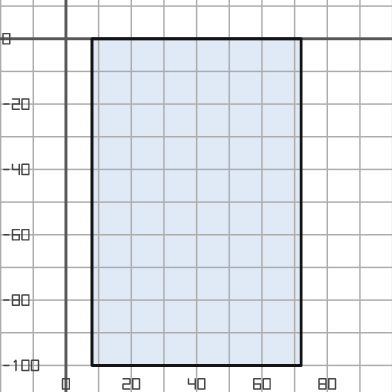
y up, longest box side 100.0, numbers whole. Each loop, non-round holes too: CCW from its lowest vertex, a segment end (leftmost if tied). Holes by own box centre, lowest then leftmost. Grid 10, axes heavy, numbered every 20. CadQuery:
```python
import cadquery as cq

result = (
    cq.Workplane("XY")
    .moveTo(8.0, -100.0)
    .lineTo(72.0, -100.0)
    .lineTo(72.0, 0.0)
    .lineTo(8.0, 0.0)
    .close()
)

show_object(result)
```